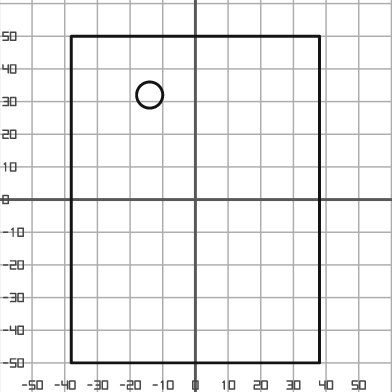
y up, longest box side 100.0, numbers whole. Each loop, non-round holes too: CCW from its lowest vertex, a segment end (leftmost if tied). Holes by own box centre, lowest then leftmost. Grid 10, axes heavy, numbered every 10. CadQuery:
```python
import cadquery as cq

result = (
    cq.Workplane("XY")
    .moveTo(-38.0, -50.0)
    .lineTo(38.0, -50.0)
    .lineTo(38.0, 50.0)
    .lineTo(-38.0, 50.0)
    .close()
    .moveTo(-14.0, 32.0)
    .circle(4.0)
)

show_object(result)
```